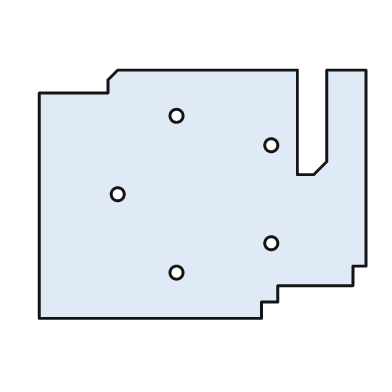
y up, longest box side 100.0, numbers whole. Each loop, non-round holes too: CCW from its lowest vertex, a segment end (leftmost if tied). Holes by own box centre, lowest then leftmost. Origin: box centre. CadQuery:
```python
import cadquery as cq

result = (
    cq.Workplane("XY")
    .moveTo(-50.0, -38.0)
    .lineTo(18.0, -38.0)
    .lineTo(18.0, -33.0)
    .lineTo(23.0, -33.0)
    .lineTo(23.0, -28.0)
    .lineTo(46.0, -28.0)
    .lineTo(46.0, -22.0)
    .lineTo(50.0, -22.0)
    .lineTo(50.0, 38.0)
    .lineTo(38.0, 38.0)
    .lineTo(38.0, 10.0)
    .lineTo(34.0, 6.0)
    .lineTo(29.0, 6.0)
    .lineTo(29.0, 38.0)
    .lineTo(-26.0, 38.0)
    .lineTo(-29.0, 35.0)
    .lineTo(-29.0, 31.0)
    .lineTo(-50.0, 31.0)
    .close()
    .moveTo(-8.0, -24.0)
    .circle(2.0)
    .moveTo(21.0, -15.0)
    .circle(2.0)
    .moveTo(-26.0, 0.0)
    .circle(2.0)
    .moveTo(21.0, 15.0)
    .circle(2.0)
    .moveTo(-8.0, 24.0)
    .circle(2.0)
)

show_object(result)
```